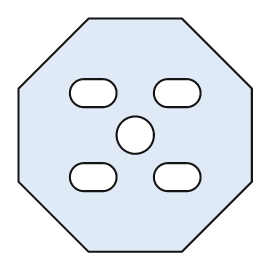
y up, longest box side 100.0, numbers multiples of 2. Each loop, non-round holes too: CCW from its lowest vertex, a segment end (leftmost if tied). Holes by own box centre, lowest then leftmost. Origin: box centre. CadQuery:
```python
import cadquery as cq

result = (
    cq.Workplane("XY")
    .moveTo(-20.0, -50.0)
    .lineTo(20.0, -50.0)
    .lineTo(50.0, -20.0)
    .lineTo(50.0, 20.0)
    .lineTo(20.0, 50.0)
    .lineTo(-20.0, 50.0)
    .lineTo(-50.0, 20.0)
    .lineTo(-50.0, -20.0)
    .close()
    .moveTo(-22.0, -24.0)
    .lineTo(-14.0, -24.0)
    .threePointArc((-8.0, -18.0), (-14.0, -12.0))
    .lineTo(-22.0, -12.0)
    .threePointArc((-28.0, -18.0), (-22.0, -24.0))
    .close()
    .moveTo(14.0, -24.0)
    .lineTo(22.0, -24.0)
    .threePointArc((28.0, -18.0), (22.0, -12.0))
    .lineTo(14.0, -12.0)
    .threePointArc((8.0, -18.0), (14.0, -24.0))
    .close()
    .moveTo(0.0, 0.0)
    .circle(8.0)
    .moveTo(-22.0, 12.0)
    .lineTo(-14.0, 12.0)
    .threePointArc((-8.0, 18.0), (-14.0, 24.0))
    .lineTo(-22.0, 24.0)
    .threePointArc((-28.0, 18.0), (-22.0, 12.0))
    .close()
    .moveTo(14.0, 12.0)
    .lineTo(22.0, 12.0)
    .threePointArc((28.0, 18.0), (22.0, 24.0))
    .lineTo(14.0, 24.0)
    .threePointArc((8.0, 18.0), (14.0, 12.0))
    .close()
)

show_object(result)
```